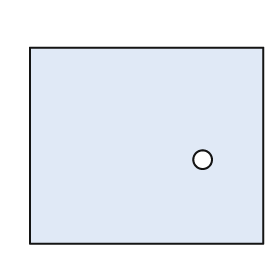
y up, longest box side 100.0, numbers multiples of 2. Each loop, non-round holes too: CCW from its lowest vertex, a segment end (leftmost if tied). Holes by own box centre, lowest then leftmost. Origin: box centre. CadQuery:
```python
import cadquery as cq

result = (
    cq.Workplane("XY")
    .moveTo(-50.0, -42.0)
    .lineTo(50.0, -42.0)
    .lineTo(50.0, 42.0)
    .lineTo(-50.0, 42.0)
    .close()
    .moveTo(24.0, -6.0)
    .circle(4.0)
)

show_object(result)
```